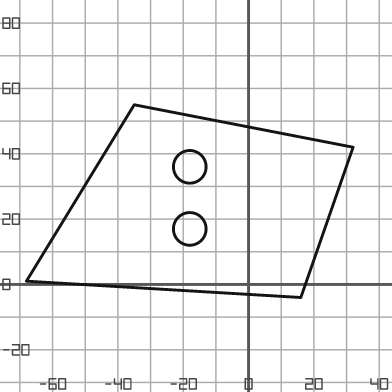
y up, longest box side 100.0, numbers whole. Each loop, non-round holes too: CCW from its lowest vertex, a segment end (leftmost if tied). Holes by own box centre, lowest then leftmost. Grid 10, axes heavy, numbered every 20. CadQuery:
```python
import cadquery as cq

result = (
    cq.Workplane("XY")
    .moveTo(16.0, -4.0)
    .lineTo(32.0, 42.0)
    .lineTo(-35.0, 55.0)
    .lineTo(-68.0, 1.0)
    .close()
    .moveTo(-18.0, 17.0)
    .circle(5.0)
    .moveTo(-18.0, 36.0)
    .circle(5.0)
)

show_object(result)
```